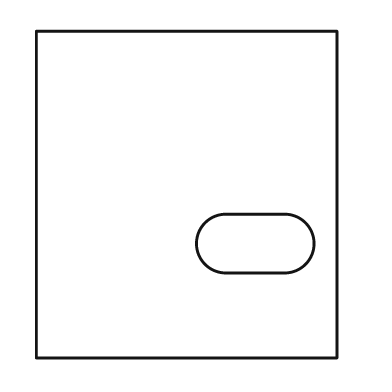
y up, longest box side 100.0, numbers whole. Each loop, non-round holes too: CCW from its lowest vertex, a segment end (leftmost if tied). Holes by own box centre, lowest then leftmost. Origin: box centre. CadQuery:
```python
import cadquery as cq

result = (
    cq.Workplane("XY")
    .moveTo(-46.0, -50.0)
    .lineTo(46.0, -50.0)
    .lineTo(46.0, 50.0)
    .lineTo(-46.0, 50.0)
    .close()
    .moveTo(12.0, -24.0)
    .lineTo(30.0, -24.0)
    .threePointArc((39.0, -15.0), (30.0, -6.0))
    .lineTo(12.0, -6.0)
    .threePointArc((3.0, -15.0), (12.0, -24.0))
    .close()
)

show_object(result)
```